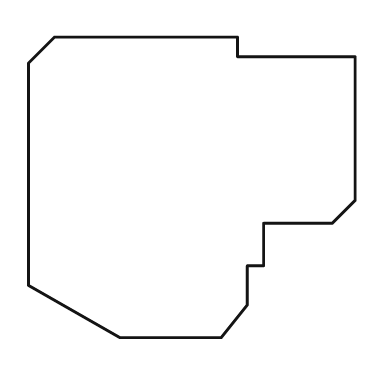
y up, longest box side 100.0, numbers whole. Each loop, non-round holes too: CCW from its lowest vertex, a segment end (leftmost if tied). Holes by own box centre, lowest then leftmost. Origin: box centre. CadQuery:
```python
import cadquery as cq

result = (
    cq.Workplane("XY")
    .moveTo(-22.0, -46.0)
    .lineTo(9.0, -46.0)
    .lineTo(17.0, -36.0)
    .lineTo(17.0, -24.0)
    .lineTo(22.0, -24.0)
    .lineTo(22.0, -11.0)
    .lineTo(43.0, -11.0)
    .lineTo(50.0, -4.0)
    .lineTo(50.0, 40.0)
    .lineTo(14.0, 40.0)
    .lineTo(14.0, 46.0)
    .lineTo(-42.0, 46.0)
    .lineTo(-50.0, 38.0)
    .lineTo(-50.0, -30.0)
    .close()
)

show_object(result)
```